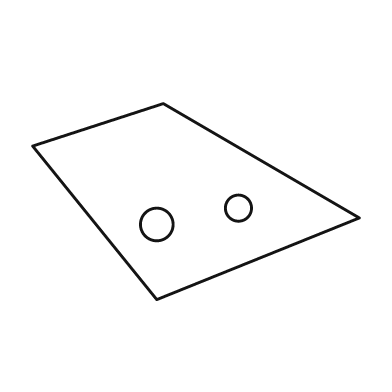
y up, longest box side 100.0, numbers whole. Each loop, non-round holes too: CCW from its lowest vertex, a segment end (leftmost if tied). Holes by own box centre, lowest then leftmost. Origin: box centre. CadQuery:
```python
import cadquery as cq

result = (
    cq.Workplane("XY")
    .moveTo(-12.0, -30.0)
    .lineTo(50.0, -5.0)
    .lineTo(-10.0, 30.0)
    .lineTo(-50.0, 17.0)
    .close()
    .moveTo(-12.0, -7.0)
    .circle(5.0)
    .moveTo(13.0, -2.0)
    .circle(4.0)
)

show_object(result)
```